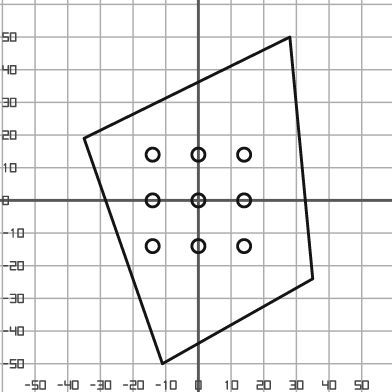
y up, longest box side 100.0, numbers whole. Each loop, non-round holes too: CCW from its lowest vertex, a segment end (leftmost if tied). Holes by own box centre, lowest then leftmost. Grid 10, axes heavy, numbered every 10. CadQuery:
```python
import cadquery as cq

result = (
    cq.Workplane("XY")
    .moveTo(-11.0, -50.0)
    .lineTo(35.0, -24.0)
    .lineTo(28.0, 50.0)
    .lineTo(-35.0, 19.0)
    .close()
    .moveTo(-14.0, -14.0)
    .circle(2.0)
    .moveTo(0.0, -14.0)
    .circle(2.0)
    .moveTo(14.0, -14.0)
    .circle(2.0)
    .moveTo(-14.0, 0.0)
    .circle(2.0)
    .moveTo(0.0, 0.0)
    .circle(2.0)
    .moveTo(14.0, 0.0)
    .circle(2.0)
    .moveTo(-14.0, 14.0)
    .circle(2.0)
    .moveTo(0.0, 14.0)
    .circle(2.0)
    .moveTo(14.0, 14.0)
    .circle(2.0)
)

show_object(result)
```